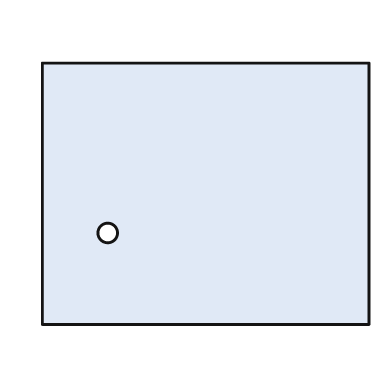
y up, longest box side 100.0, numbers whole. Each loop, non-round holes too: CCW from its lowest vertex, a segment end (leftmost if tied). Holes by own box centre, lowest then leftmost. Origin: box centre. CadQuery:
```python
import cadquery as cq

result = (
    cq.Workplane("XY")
    .moveTo(-50.0, -40.0)
    .lineTo(50.0, -40.0)
    .lineTo(50.0, 40.0)
    .lineTo(-50.0, 40.0)
    .close()
    .moveTo(-30.0, -12.0)
    .circle(3.0)
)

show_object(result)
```